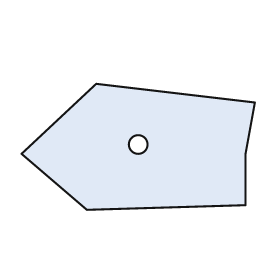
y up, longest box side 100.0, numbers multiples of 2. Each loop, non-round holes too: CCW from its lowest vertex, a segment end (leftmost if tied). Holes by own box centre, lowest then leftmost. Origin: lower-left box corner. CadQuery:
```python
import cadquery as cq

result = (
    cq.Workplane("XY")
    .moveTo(28.0, 0.0)
    .lineTo(96.0, 2.0)
    .lineTo(96.0, 24.0)
    .lineTo(100.0, 46.0)
    .lineTo(32.0, 54.0)
    .lineTo(0.0, 24.0)
    .close()
    .moveTo(50.0, 28.0)
    .circle(4.0)
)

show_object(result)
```